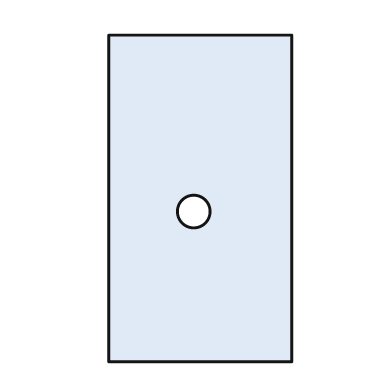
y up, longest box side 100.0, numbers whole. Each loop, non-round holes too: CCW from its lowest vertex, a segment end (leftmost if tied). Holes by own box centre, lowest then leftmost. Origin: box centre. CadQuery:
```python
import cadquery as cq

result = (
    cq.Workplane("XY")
    .moveTo(-28.0, -50.0)
    .lineTo(28.0, -50.0)
    .lineTo(28.0, 50.0)
    .lineTo(-28.0, 50.0)
    .close()
    .moveTo(-2.0, -4.0)
    .circle(5.0)
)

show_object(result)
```